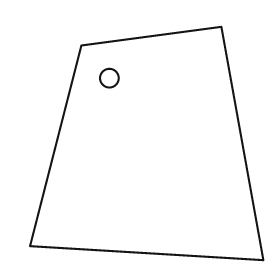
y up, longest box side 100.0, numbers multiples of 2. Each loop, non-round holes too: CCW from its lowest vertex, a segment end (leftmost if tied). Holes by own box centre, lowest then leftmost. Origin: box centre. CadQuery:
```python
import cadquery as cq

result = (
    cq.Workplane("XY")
    .moveTo(50.0, -50.0)
    .lineTo(32.0, 50.0)
    .lineTo(-28.0, 42.0)
    .lineTo(-50.0, -44.0)
    .close()
    .moveTo(-16.0, 28.0)
    .circle(4.0)
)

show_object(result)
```